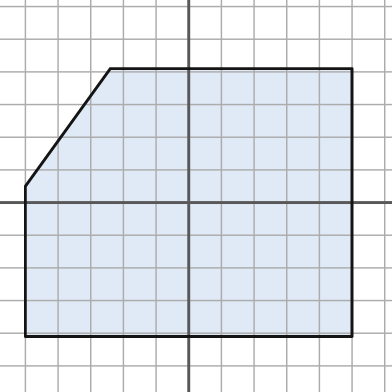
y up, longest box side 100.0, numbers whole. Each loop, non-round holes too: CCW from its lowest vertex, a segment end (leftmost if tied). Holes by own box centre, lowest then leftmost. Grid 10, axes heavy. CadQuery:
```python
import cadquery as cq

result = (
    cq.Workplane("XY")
    .moveTo(-50.0, -41.0)
    .lineTo(50.0, -41.0)
    .lineTo(50.0, 41.0)
    .lineTo(-24.0, 41.0)
    .lineTo(-50.0, 5.0)
    .close()
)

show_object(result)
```